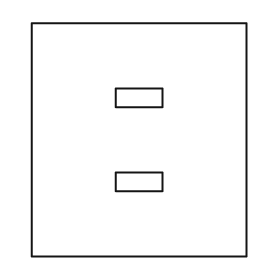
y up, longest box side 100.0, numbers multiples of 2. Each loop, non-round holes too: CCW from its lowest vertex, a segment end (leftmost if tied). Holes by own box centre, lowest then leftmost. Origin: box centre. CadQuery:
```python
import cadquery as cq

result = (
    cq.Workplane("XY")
    .moveTo(-46.0, -50.0)
    .lineTo(46.0, -50.0)
    .lineTo(46.0, 50.0)
    .lineTo(-46.0, 50.0)
    .close()
    .moveTo(-10.0, -22.0)
    .lineTo(10.0, -22.0)
    .lineTo(10.0, -14.0)
    .lineTo(-10.0, -14.0)
    .close()
    .moveTo(-10.0, 14.0)
    .lineTo(10.0, 14.0)
    .lineTo(10.0, 22.0)
    .lineTo(-10.0, 22.0)
    .close()
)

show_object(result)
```